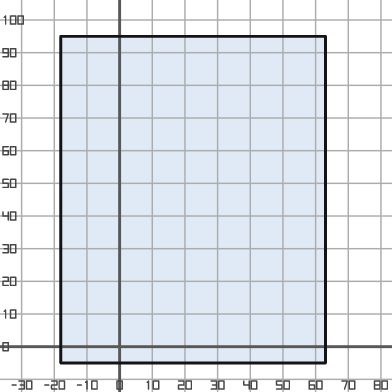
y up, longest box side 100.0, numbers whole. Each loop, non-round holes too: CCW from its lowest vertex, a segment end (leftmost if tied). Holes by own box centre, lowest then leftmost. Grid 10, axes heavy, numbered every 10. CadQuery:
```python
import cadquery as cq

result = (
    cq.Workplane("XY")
    .moveTo(-18.0, -5.0)
    .lineTo(63.0, -5.0)
    .lineTo(63.0, 95.0)
    .lineTo(-18.0, 95.0)
    .close()
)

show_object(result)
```